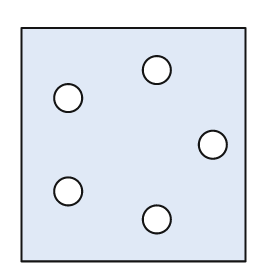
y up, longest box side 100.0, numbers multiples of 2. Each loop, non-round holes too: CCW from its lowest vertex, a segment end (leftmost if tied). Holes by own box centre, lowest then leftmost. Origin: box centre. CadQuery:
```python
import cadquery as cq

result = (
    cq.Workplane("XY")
    .moveTo(-48.0, -50.0)
    .lineTo(48.0, -50.0)
    .lineTo(48.0, 50.0)
    .lineTo(-48.0, 50.0)
    .close()
    .moveTo(10.0, -32.0)
    .circle(6.0)
    .moveTo(-28.0, -20.0)
    .circle(6.0)
    .moveTo(34.0, 0.0)
    .circle(6.0)
    .moveTo(-28.0, 20.0)
    .circle(6.0)
    .moveTo(10.0, 32.0)
    .circle(6.0)
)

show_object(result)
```